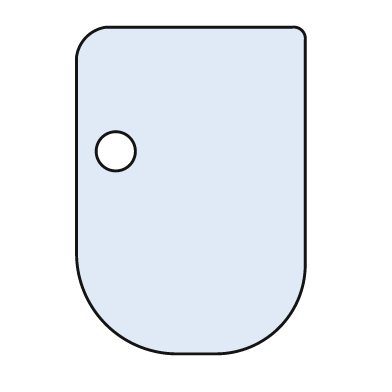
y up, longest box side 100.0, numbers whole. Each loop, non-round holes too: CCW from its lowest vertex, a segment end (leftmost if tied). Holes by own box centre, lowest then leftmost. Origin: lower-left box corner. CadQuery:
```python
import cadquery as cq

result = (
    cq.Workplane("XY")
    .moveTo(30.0, 0.0)
    .lineTo(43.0, 0.0)
    .threePointArc((62.0, 8.0), (70.0, 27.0))
    .lineTo(70.0, 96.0)
    .threePointArc((69.0, 99.0), (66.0, 100.0))
    .lineTo(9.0, 100.0)
    .threePointArc((3.0, 97.0), (0.0, 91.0))
    .lineTo(0.0, 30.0)
    .threePointArc((9.0, 9.0), (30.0, 0.0))
    .close()
    .moveTo(12.0, 62.0)
    .circle(6.0)
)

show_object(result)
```